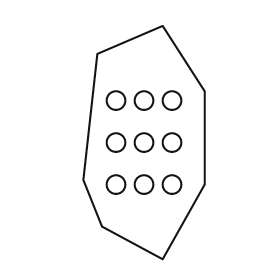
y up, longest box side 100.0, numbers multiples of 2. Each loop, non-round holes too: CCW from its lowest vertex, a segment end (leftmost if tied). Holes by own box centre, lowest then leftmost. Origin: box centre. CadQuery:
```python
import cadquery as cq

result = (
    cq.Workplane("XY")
    .moveTo(8.0, -50.0)
    .lineTo(26.0, -18.0)
    .lineTo(26.0, 22.0)
    .lineTo(8.0, 50.0)
    .lineTo(-20.0, 38.0)
    .lineTo(-26.0, -16.0)
    .lineTo(-18.0, -36.0)
    .close()
    .moveTo(-12.0, -18.0)
    .circle(4.0)
    .moveTo(0.0, -18.0)
    .circle(4.0)
    .moveTo(12.0, -18.0)
    .circle(4.0)
    .moveTo(-12.0, 0.0)
    .circle(4.0)
    .moveTo(0.0, 0.0)
    .circle(4.0)
    .moveTo(12.0, 0.0)
    .circle(4.0)
    .moveTo(-12.0, 18.0)
    .circle(4.0)
    .moveTo(0.0, 18.0)
    .circle(4.0)
    .moveTo(12.0, 18.0)
    .circle(4.0)
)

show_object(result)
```